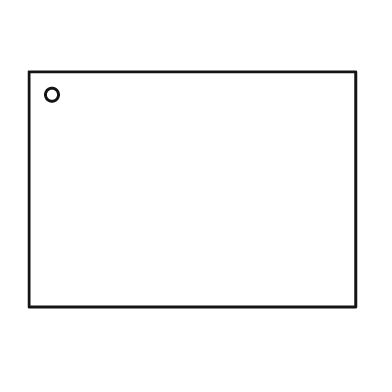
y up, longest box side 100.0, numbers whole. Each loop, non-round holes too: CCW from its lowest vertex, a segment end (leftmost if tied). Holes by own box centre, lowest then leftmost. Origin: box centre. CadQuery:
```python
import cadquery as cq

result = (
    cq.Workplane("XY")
    .moveTo(-50.0, -36.0)
    .lineTo(50.0, -36.0)
    .lineTo(50.0, 36.0)
    .lineTo(-50.0, 36.0)
    .close()
    .moveTo(-43.0, 29.0)
    .circle(2.0)
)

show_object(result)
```